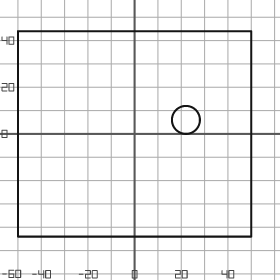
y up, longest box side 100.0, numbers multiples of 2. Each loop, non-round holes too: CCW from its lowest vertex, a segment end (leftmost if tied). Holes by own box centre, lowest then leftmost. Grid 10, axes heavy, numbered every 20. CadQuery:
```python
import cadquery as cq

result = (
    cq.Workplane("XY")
    .moveTo(-50.0, -44.0)
    .lineTo(50.0, -44.0)
    .lineTo(50.0, 44.0)
    .lineTo(-50.0, 44.0)
    .close()
    .moveTo(22.0, 6.0)
    .circle(6.0)
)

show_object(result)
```